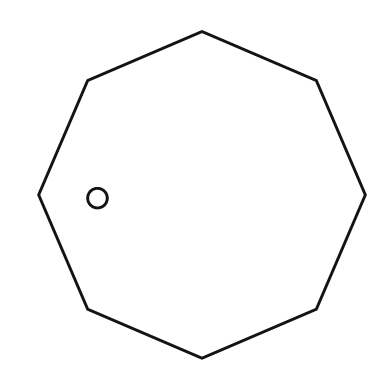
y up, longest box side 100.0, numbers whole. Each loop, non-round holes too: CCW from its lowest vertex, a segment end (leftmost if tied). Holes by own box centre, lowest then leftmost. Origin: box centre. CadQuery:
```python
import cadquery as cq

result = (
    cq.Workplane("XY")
    .moveTo(0.0, -50.0)
    .lineTo(35.0, -35.0)
    .lineTo(50.0, 0.0)
    .lineTo(35.0, 35.0)
    .lineTo(0.0, 50.0)
    .lineTo(-35.0, 35.0)
    .lineTo(-50.0, 0.0)
    .lineTo(-35.0, -35.0)
    .close()
    .moveTo(-32.0, -1.0)
    .circle(3.0)
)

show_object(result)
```